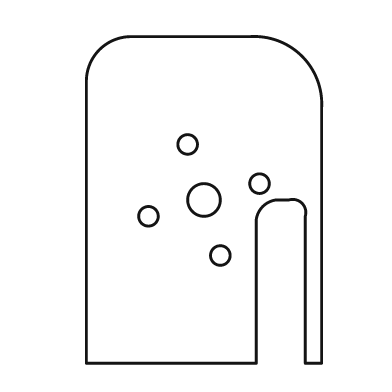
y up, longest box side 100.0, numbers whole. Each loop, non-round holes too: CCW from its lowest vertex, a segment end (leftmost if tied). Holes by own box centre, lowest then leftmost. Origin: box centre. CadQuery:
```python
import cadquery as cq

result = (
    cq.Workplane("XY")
    .moveTo(-36.0, -50.0)
    .lineTo(16.0, -50.0)
    .lineTo(16.0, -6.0)
    .threePointArc((18.0, -2.0), (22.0, 0.0))
    .lineTo(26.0, 0.0)
    .threePointArc((30.0, -1.0), (31.0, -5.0))
    .lineTo(31.0, -50.0)
    .lineTo(36.0, -50.0)
    .lineTo(36.0, 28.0)
    .threePointArc((30.0, 44.0), (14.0, 50.0))
    .lineTo(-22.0, 50.0)
    .threePointArc((-32.0, 46.0), (-36.0, 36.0))
    .close()
    .moveTo(5.0, -17.0)
    .circle(3.0)
    .moveTo(-17.0, -5.0)
    .circle(3.0)
    .moveTo(0.0, 0.0)
    .circle(5.0)
    .moveTo(17.0, 5.0)
    .circle(3.0)
    .moveTo(-5.0, 17.0)
    .circle(3.0)
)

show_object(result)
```